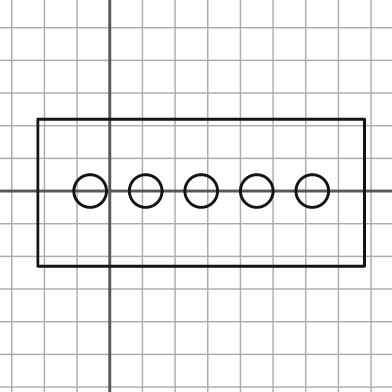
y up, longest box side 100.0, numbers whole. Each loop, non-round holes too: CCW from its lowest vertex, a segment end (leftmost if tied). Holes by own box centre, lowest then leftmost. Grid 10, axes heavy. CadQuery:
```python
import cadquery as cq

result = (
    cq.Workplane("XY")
    .moveTo(-22.0, -23.0)
    .lineTo(78.0, -23.0)
    .lineTo(78.0, 22.0)
    .lineTo(-22.0, 22.0)
    .close()
    .moveTo(-6.0, 0.0)
    .circle(5.0)
    .moveTo(11.0, 0.0)
    .circle(5.0)
    .moveTo(28.0, 0.0)
    .circle(5.0)
    .moveTo(45.0, 0.0)
    .circle(5.0)
    .moveTo(62.0, 0.0)
    .circle(5.0)
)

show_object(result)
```